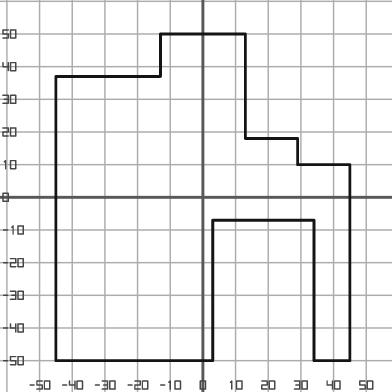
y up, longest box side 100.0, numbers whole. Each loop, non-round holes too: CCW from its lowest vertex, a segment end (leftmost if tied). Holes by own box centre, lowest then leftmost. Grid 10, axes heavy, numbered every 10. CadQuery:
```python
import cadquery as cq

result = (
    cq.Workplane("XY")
    .moveTo(-45.0, -50.0)
    .lineTo(3.0, -50.0)
    .lineTo(3.0, -7.0)
    .lineTo(34.0, -7.0)
    .lineTo(34.0, -50.0)
    .lineTo(45.0, -50.0)
    .lineTo(45.0, 10.0)
    .lineTo(29.0, 10.0)
    .lineTo(29.0, 18.0)
    .lineTo(13.0, 18.0)
    .lineTo(13.0, 50.0)
    .lineTo(-13.0, 50.0)
    .lineTo(-13.0, 37.0)
    .lineTo(-45.0, 37.0)
    .close()
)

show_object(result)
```